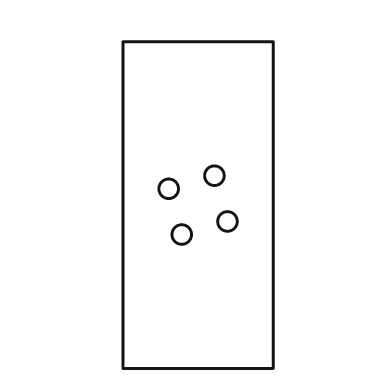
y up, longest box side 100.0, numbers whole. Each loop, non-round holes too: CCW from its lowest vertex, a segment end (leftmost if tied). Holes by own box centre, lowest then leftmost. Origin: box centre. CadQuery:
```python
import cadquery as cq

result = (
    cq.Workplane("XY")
    .moveTo(-23.0, -50.0)
    .lineTo(23.0, -50.0)
    .lineTo(23.0, 50.0)
    .lineTo(-23.0, 50.0)
    .close()
    .moveTo(-5.0, -9.0)
    .circle(3.0)
    .moveTo(9.0, -5.0)
    .circle(3.0)
    .moveTo(-9.0, 5.0)
    .circle(3.0)
    .moveTo(5.0, 9.0)
    .circle(3.0)
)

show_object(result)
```